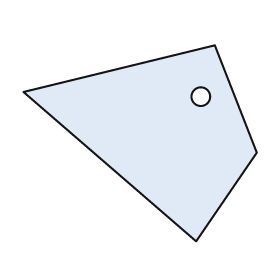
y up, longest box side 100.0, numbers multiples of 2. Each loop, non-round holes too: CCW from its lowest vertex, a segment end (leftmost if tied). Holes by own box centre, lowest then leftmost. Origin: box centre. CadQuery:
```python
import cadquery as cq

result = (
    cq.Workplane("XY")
    .moveTo(24.0, -42.0)
    .lineTo(50.0, -4.0)
    .lineTo(32.0, 42.0)
    .lineTo(-50.0, 22.0)
    .close()
    .moveTo(26.0, 20.0)
    .circle(4.0)
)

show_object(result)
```